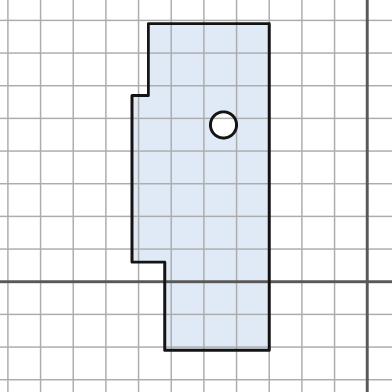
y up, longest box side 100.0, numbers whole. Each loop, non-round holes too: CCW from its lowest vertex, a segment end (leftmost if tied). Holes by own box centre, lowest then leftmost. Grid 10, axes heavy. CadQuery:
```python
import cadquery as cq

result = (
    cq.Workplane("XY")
    .moveTo(-62.0, -21.0)
    .lineTo(-30.0, -21.0)
    .lineTo(-30.0, 79.0)
    .lineTo(-67.0, 79.0)
    .lineTo(-67.0, 57.0)
    .lineTo(-72.0, 57.0)
    .lineTo(-72.0, 6.0)
    .lineTo(-62.0, 6.0)
    .close()
    .moveTo(-44.0, 48.0)
    .circle(4.0)
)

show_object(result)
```